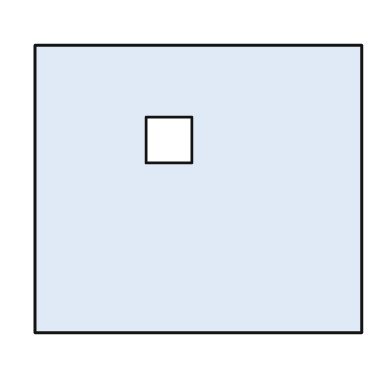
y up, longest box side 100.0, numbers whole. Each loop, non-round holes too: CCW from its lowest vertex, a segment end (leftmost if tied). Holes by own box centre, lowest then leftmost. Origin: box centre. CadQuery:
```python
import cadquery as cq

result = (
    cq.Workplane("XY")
    .moveTo(-50.0, -44.0)
    .lineTo(50.0, -44.0)
    .lineTo(50.0, 44.0)
    .lineTo(-50.0, 44.0)
    .close()
    .moveTo(-16.0, 8.0)
    .lineTo(-2.0, 8.0)
    .lineTo(-2.0, 22.0)
    .lineTo(-16.0, 22.0)
    .close()
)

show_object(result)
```